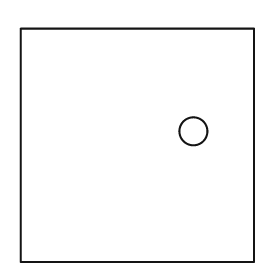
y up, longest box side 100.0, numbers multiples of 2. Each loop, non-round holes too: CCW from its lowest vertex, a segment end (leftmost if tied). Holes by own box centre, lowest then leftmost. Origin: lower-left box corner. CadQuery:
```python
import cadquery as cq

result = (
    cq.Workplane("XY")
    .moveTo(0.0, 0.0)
    .lineTo(100.0, 0.0)
    .lineTo(100.0, 100.0)
    .lineTo(0.0, 100.0)
    .close()
    .moveTo(74.0, 56.0)
    .circle(6.0)
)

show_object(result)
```